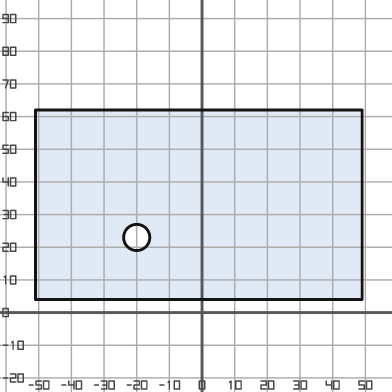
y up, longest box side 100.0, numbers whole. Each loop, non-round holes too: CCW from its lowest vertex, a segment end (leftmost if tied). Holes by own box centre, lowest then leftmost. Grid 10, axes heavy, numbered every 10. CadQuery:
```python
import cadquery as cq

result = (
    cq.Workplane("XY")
    .moveTo(-51.0, 4.0)
    .lineTo(49.0, 4.0)
    .lineTo(49.0, 62.0)
    .lineTo(-51.0, 62.0)
    .close()
    .moveTo(-20.0, 23.0)
    .circle(4.0)
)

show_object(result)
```